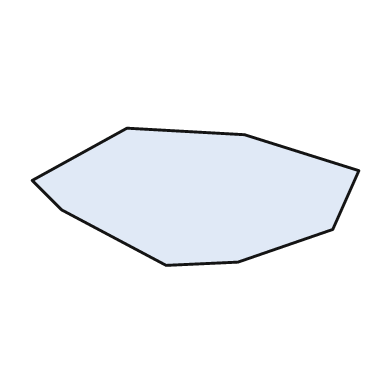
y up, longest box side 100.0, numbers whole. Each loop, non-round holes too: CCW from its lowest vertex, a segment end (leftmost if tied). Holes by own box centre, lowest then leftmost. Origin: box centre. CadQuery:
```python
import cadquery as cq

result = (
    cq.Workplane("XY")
    .moveTo(-9.0, -21.0)
    .lineTo(13.0, -20.0)
    .lineTo(42.0, -10.0)
    .lineTo(50.0, 8.0)
    .lineTo(15.0, 19.0)
    .lineTo(-21.0, 21.0)
    .lineTo(-50.0, 5.0)
    .lineTo(-41.0, -4.0)
    .close()
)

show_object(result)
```